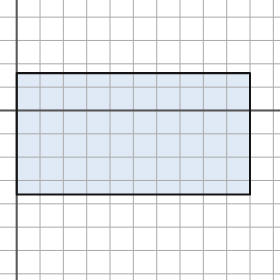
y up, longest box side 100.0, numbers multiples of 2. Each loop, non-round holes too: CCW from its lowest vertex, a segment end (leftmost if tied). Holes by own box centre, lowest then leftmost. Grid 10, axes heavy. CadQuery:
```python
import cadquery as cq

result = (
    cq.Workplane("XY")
    .moveTo(0.0, -36.0)
    .lineTo(100.0, -36.0)
    .lineTo(100.0, 16.0)
    .lineTo(0.0, 16.0)
    .close()
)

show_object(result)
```